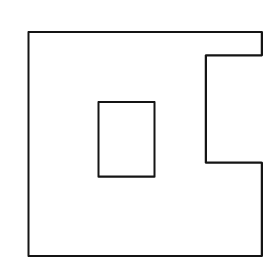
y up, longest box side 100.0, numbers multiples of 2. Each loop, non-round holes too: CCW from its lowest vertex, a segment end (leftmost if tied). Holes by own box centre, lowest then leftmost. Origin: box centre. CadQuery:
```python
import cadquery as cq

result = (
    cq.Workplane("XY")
    .moveTo(-50.0, -48.0)
    .lineTo(50.0, -48.0)
    .lineTo(50.0, -8.0)
    .lineTo(26.0, -8.0)
    .lineTo(26.0, 38.0)
    .lineTo(50.0, 38.0)
    .lineTo(50.0, 48.0)
    .lineTo(-50.0, 48.0)
    .close()
    .moveTo(-20.0, -14.0)
    .lineTo(4.0, -14.0)
    .lineTo(4.0, 18.0)
    .lineTo(-20.0, 18.0)
    .close()
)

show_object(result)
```